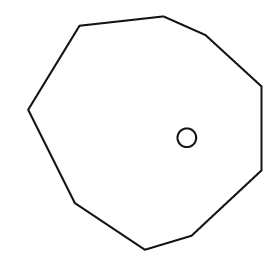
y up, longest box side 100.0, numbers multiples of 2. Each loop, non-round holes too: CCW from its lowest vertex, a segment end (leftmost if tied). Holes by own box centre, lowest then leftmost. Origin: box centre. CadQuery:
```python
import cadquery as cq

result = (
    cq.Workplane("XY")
    .moveTo(0.0, -50.0)
    .lineTo(20.0, -44.0)
    .lineTo(50.0, -16.0)
    .lineTo(50.0, 20.0)
    .lineTo(26.0, 42.0)
    .lineTo(8.0, 50.0)
    .lineTo(-28.0, 46.0)
    .lineTo(-50.0, 10.0)
    .lineTo(-30.0, -30.0)
    .close()
    .moveTo(18.0, -2.0)
    .circle(4.0)
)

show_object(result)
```